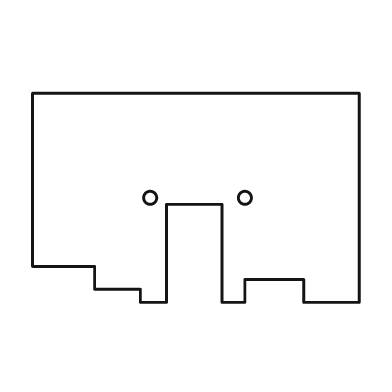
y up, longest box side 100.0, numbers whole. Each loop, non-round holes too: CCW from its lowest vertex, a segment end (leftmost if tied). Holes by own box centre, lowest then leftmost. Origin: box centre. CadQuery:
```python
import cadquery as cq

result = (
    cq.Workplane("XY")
    .moveTo(-17.0, -32.0)
    .lineTo(-9.0, -32.0)
    .lineTo(-9.0, -2.0)
    .lineTo(8.0, -2.0)
    .lineTo(8.0, -32.0)
    .lineTo(15.0, -32.0)
    .lineTo(15.0, -25.0)
    .lineTo(33.0, -25.0)
    .lineTo(33.0, -32.0)
    .lineTo(50.0, -32.0)
    .lineTo(50.0, 32.0)
    .lineTo(-50.0, 32.0)
    .lineTo(-50.0, -21.0)
    .lineTo(-31.0, -21.0)
    .lineTo(-31.0, -28.0)
    .lineTo(-17.0, -28.0)
    .close()
    .moveTo(-14.0, 0.0)
    .circle(2.0)
    .moveTo(15.0, 0.0)
    .circle(2.0)
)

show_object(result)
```